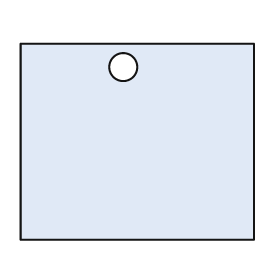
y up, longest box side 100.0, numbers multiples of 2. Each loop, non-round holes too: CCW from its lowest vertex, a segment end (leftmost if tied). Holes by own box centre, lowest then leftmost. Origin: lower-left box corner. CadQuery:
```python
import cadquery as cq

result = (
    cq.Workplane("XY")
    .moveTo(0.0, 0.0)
    .lineTo(100.0, 0.0)
    .lineTo(100.0, 84.0)
    .lineTo(0.0, 84.0)
    .close()
    .moveTo(44.0, 74.0)
    .circle(6.0)
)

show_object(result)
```